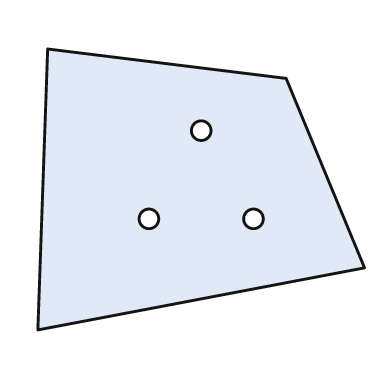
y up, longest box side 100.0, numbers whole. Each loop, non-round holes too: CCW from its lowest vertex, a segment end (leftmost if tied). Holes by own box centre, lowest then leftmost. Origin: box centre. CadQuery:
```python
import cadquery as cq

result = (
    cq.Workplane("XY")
    .moveTo(-50.0, -43.0)
    .lineTo(50.0, -24.0)
    .lineTo(26.0, 34.0)
    .lineTo(-47.0, 43.0)
    .close()
    .moveTo(-16.0, -9.0)
    .circle(3.0)
    .moveTo(16.0, -9.0)
    .circle(3.0)
    .moveTo(0.0, 18.0)
    .circle(3.0)
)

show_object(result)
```